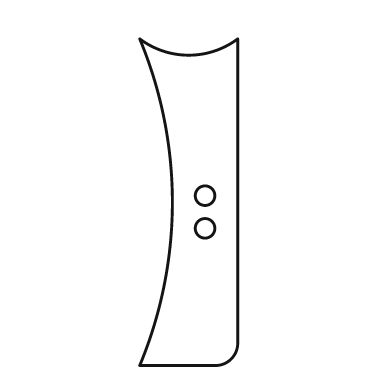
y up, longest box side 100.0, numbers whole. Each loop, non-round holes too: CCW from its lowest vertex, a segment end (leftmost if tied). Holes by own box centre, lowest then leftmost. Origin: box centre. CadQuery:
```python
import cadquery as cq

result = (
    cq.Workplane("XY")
    .moveTo(-15.0, -50.0)
    .lineTo(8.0, -50.0)
    .threePointArc((13.0, -48.0), (15.0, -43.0))
    .lineTo(15.0, 50.0)
    .threePointArc((0.0, 45.0), (-15.0, 50.0))
    .threePointArc((-5.0, 0.0), (-15.0, -50.0))
    .close()
    .moveTo(5.0, -8.0)
    .circle(3.0)
    .moveTo(5.0, 2.0)
    .circle(3.0)
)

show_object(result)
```